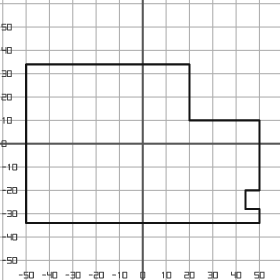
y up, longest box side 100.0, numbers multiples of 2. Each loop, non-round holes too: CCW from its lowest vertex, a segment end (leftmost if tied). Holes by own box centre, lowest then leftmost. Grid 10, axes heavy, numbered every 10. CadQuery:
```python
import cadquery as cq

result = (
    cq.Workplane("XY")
    .moveTo(-50.0, -34.0)
    .lineTo(50.0, -34.0)
    .lineTo(50.0, -28.0)
    .lineTo(44.0, -28.0)
    .lineTo(44.0, -20.0)
    .lineTo(50.0, -20.0)
    .lineTo(50.0, 10.0)
    .lineTo(20.0, 10.0)
    .lineTo(20.0, 34.0)
    .lineTo(-50.0, 34.0)
    .close()
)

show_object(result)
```